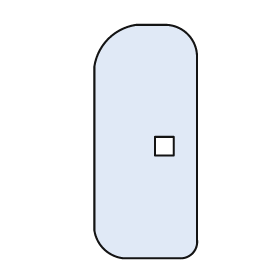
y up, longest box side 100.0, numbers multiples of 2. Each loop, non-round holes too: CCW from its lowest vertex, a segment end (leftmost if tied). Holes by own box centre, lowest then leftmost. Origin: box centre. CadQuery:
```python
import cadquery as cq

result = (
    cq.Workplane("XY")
    .moveTo(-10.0, -50.0)
    .lineTo(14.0, -50.0)
    .threePointArc((20.0, -48.0), (22.0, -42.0))
    .lineTo(22.0, 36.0)
    .threePointArc((18.0, 46.0), (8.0, 50.0))
    .lineTo(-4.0, 50.0)
    .threePointArc((-16.0, 44.0), (-22.0, 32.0))
    .lineTo(-22.0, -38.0)
    .threePointArc((-18.0, -46.0), (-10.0, -50.0))
    .close()
    .moveTo(4.0, -6.0)
    .lineTo(12.0, -6.0)
    .lineTo(12.0, 2.0)
    .lineTo(4.0, 2.0)
    .close()
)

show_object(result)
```